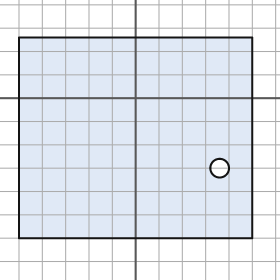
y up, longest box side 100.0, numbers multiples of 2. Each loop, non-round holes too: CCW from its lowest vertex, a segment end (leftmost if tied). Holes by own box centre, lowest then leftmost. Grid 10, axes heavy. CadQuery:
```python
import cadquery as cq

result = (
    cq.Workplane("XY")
    .moveTo(-50.0, -60.0)
    .lineTo(50.0, -60.0)
    .lineTo(50.0, 26.0)
    .lineTo(-50.0, 26.0)
    .close()
    .moveTo(36.0, -30.0)
    .circle(4.0)
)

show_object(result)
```